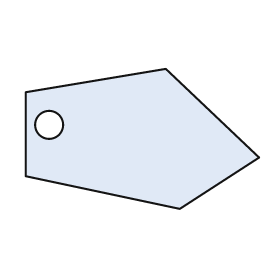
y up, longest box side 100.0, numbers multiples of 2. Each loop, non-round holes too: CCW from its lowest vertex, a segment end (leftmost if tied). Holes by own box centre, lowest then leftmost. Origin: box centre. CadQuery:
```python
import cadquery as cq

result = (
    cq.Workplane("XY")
    .moveTo(16.0, -30.0)
    .lineTo(50.0, -8.0)
    .lineTo(10.0, 30.0)
    .lineTo(-50.0, 20.0)
    .lineTo(-50.0, -16.0)
    .close()
    .moveTo(-40.0, 6.0)
    .circle(6.0)
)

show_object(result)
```